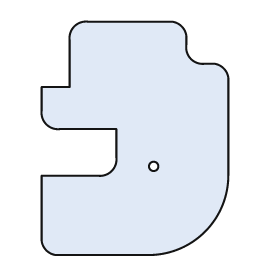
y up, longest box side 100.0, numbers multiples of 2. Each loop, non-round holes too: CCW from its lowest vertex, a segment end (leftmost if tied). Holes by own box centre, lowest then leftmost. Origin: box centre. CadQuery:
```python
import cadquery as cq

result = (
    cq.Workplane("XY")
    .moveTo(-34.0, -50.0)
    .lineTo(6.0, -50.0)
    .threePointArc((30.0, -40.0), (40.0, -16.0))
    .lineTo(40.0, 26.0)
    .threePointArc((38.0, 30.0), (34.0, 32.0))
    .lineTo(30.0, 32.0)
    .threePointArc((24.0, 34.0), (22.0, 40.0))
    .lineTo(22.0, 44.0)
    .threePointArc((20.0, 48.0), (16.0, 50.0))
    .lineTo(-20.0, 50.0)
    .threePointArc((-26.0, 48.0), (-28.0, 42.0))
    .lineTo(-28.0, 22.0)
    .lineTo(-40.0, 22.0)
    .lineTo(-40.0, 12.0)
    .threePointArc((-38.0, 6.0), (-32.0, 4.0))
    .lineTo(-8.0, 4.0)
    .lineTo(-8.0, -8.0)
    .threePointArc((-10.0, -14.0), (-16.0, -16.0))
    .lineTo(-40.0, -16.0)
    .lineTo(-40.0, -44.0)
    .threePointArc((-38.0, -48.0), (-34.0, -50.0))
    .close()
    .moveTo(8.0, -12.0)
    .circle(2.0)
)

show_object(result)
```